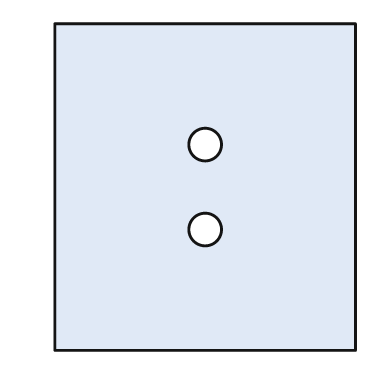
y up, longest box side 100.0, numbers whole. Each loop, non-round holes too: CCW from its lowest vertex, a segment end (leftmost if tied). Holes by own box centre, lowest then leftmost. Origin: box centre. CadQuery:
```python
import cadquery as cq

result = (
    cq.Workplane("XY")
    .moveTo(-46.0, -50.0)
    .lineTo(46.0, -50.0)
    .lineTo(46.0, 50.0)
    .lineTo(-46.0, 50.0)
    .close()
    .moveTo(0.0, -13.0)
    .circle(5.0)
    .moveTo(0.0, 13.0)
    .circle(5.0)
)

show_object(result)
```